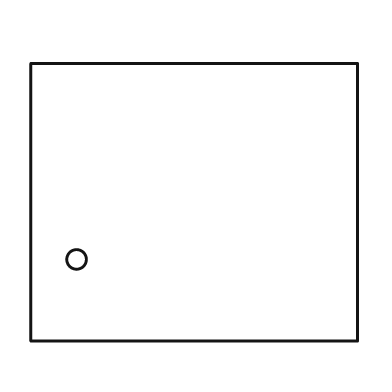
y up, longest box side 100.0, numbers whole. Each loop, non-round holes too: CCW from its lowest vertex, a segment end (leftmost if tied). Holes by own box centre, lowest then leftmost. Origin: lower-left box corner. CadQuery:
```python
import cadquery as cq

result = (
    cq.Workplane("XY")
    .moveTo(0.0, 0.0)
    .lineTo(100.0, 0.0)
    .lineTo(100.0, 85.0)
    .lineTo(0.0, 85.0)
    .close()
    .moveTo(14.0, 25.0)
    .circle(3.0)
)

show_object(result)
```